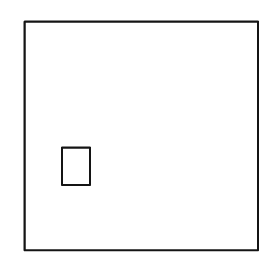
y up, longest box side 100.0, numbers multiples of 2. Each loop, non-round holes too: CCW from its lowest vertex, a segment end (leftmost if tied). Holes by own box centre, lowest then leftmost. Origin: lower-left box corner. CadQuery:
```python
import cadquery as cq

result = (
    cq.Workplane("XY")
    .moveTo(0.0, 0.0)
    .lineTo(100.0, 0.0)
    .lineTo(100.0, 98.0)
    .lineTo(0.0, 98.0)
    .close()
    .moveTo(16.0, 28.0)
    .lineTo(28.0, 28.0)
    .lineTo(28.0, 44.0)
    .lineTo(16.0, 44.0)
    .close()
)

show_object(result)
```